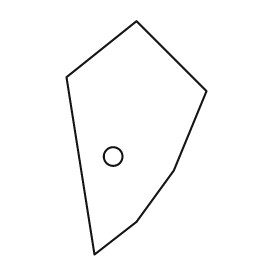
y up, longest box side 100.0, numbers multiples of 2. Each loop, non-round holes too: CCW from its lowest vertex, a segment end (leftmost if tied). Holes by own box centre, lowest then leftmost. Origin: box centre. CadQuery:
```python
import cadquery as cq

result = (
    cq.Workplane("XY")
    .moveTo(-18.0, -50.0)
    .lineTo(0.0, -36.0)
    .lineTo(16.0, -14.0)
    .lineTo(30.0, 20.0)
    .lineTo(0.0, 50.0)
    .lineTo(-30.0, 26.0)
    .close()
    .moveTo(-10.0, -8.0)
    .circle(4.0)
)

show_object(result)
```